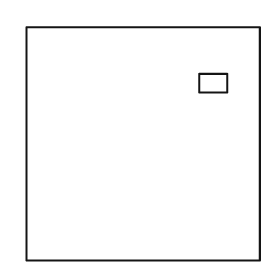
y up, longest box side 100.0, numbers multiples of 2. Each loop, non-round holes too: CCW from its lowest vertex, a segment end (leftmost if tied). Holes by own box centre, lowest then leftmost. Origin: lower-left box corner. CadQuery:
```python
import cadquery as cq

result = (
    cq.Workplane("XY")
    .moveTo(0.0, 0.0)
    .lineTo(100.0, 0.0)
    .lineTo(100.0, 100.0)
    .lineTo(0.0, 100.0)
    .close()
    .moveTo(74.0, 72.0)
    .lineTo(86.0, 72.0)
    .lineTo(86.0, 80.0)
    .lineTo(74.0, 80.0)
    .close()
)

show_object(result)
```